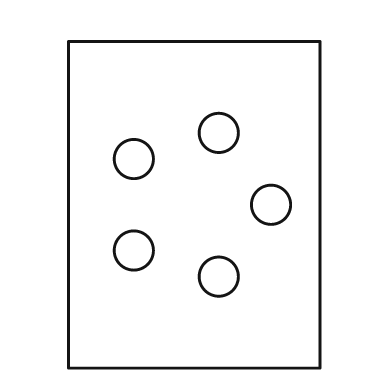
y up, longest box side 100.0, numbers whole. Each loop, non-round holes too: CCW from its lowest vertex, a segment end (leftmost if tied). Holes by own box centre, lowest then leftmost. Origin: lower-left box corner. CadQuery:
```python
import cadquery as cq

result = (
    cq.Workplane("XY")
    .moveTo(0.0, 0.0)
    .lineTo(77.0, 0.0)
    .lineTo(77.0, 100.0)
    .lineTo(0.0, 100.0)
    .close()
    .moveTo(46.0, 28.0)
    .circle(6.0)
    .moveTo(20.0, 36.0)
    .circle(6.0)
    .moveTo(62.0, 50.0)
    .circle(6.0)
    .moveTo(20.0, 64.0)
    .circle(6.0)
    .moveTo(46.0, 72.0)
    .circle(6.0)
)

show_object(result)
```